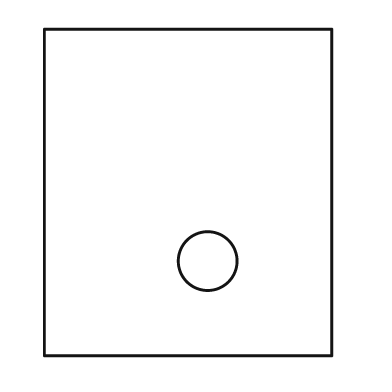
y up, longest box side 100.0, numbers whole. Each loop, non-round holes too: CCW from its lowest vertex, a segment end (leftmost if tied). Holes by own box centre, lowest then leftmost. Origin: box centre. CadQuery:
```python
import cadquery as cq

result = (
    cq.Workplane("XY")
    .moveTo(-44.0, -50.0)
    .lineTo(44.0, -50.0)
    .lineTo(44.0, 50.0)
    .lineTo(-44.0, 50.0)
    .close()
    .moveTo(6.0, -21.0)
    .circle(9.0)
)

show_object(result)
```